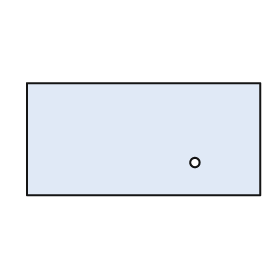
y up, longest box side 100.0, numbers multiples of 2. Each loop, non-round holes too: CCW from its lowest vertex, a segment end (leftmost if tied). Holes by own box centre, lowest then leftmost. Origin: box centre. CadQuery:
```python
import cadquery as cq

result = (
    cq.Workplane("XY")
    .moveTo(-50.0, -24.0)
    .lineTo(50.0, -24.0)
    .lineTo(50.0, 24.0)
    .lineTo(-50.0, 24.0)
    .close()
    .moveTo(22.0, -10.0)
    .circle(2.0)
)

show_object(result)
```